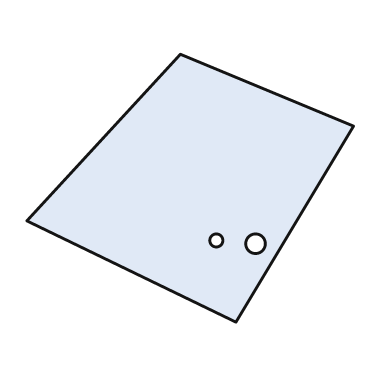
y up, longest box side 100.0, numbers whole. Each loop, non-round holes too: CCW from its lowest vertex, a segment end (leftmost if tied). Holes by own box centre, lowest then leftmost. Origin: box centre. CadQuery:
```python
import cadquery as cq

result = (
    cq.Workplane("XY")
    .moveTo(14.0, -41.0)
    .lineTo(50.0, 19.0)
    .lineTo(-3.0, 41.0)
    .lineTo(-50.0, -10.0)
    .close()
    .moveTo(20.0, -17.0)
    .circle(3.0)
    .moveTo(8.0, -16.0)
    .circle(2.0)
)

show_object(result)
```